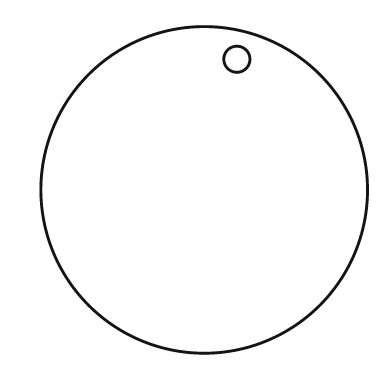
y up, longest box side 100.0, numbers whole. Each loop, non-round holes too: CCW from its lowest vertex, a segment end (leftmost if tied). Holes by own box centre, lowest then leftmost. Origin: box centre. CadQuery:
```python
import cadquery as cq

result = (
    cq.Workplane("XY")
    .moveTo(0.0, 0.0)
    .circle(50.0)
    .moveTo(10.0, 40.0)
    .circle(4.0)
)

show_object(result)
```